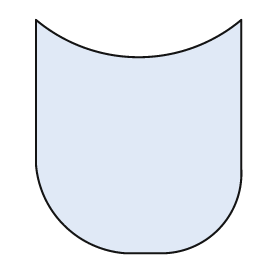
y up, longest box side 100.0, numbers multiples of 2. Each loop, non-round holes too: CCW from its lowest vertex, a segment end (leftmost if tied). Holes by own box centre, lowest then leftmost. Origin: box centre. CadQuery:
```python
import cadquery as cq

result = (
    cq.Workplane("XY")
    .moveTo(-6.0, -50.0)
    .lineTo(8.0, -50.0)
    .threePointArc((34.0, -40.0), (44.0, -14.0))
    .lineTo(44.0, 50.0)
    .threePointArc((0.0, 34.0), (-44.0, 50.0))
    .lineTo(-44.0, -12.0)
    .threePointArc((-32.0, -38.0), (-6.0, -50.0))
    .close()
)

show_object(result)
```